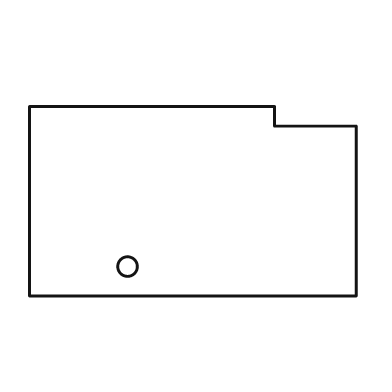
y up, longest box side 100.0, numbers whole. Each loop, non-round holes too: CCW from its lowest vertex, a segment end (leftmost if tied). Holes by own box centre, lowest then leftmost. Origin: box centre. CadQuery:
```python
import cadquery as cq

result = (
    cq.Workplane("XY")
    .moveTo(-50.0, -29.0)
    .lineTo(50.0, -29.0)
    .lineTo(50.0, 23.0)
    .lineTo(25.0, 23.0)
    .lineTo(25.0, 29.0)
    .lineTo(-50.0, 29.0)
    .close()
    .moveTo(-20.0, -20.0)
    .circle(3.0)
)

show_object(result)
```